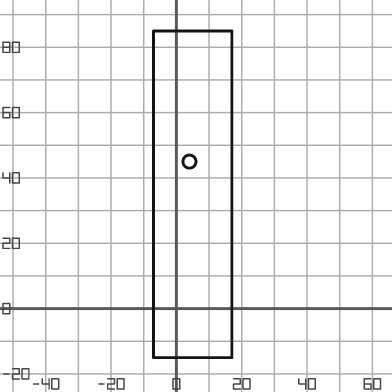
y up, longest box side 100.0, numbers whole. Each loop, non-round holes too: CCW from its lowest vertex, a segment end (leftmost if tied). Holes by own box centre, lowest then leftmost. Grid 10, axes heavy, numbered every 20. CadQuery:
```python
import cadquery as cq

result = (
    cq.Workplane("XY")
    .moveTo(-7.0, -15.0)
    .lineTo(17.0, -15.0)
    .lineTo(17.0, 85.0)
    .lineTo(-7.0, 85.0)
    .close()
    .moveTo(4.0, 45.0)
    .circle(2.0)
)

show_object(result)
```